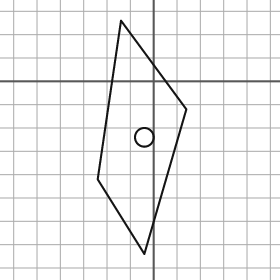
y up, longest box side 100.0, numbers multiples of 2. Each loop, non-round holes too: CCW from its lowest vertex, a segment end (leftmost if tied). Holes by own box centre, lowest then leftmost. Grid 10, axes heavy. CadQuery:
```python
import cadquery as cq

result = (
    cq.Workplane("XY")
    .moveTo(-4.0, -74.0)
    .lineTo(14.0, -12.0)
    .lineTo(-14.0, 26.0)
    .lineTo(-24.0, -42.0)
    .close()
    .moveTo(-4.0, -24.0)
    .circle(4.0)
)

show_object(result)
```